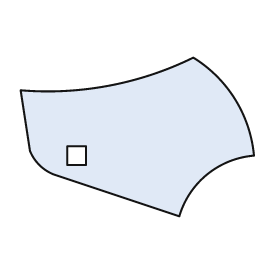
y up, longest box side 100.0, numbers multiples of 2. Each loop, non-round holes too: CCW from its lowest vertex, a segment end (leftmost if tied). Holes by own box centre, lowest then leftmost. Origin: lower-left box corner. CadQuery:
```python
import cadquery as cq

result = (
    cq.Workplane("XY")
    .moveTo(68.0, 0.0)
    .threePointArc((80.0, 18.0), (100.0, 26.0))
    .threePointArc((92.0, 50.0), (74.0, 68.0))
    .threePointArc((38.0, 56.0), (0.0, 54.0))
    .lineTo(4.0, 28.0)
    .threePointArc((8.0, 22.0), (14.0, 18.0))
    .close()
    .moveTo(20.0, 22.0)
    .lineTo(28.0, 22.0)
    .lineTo(28.0, 30.0)
    .lineTo(20.0, 30.0)
    .close()
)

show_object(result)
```